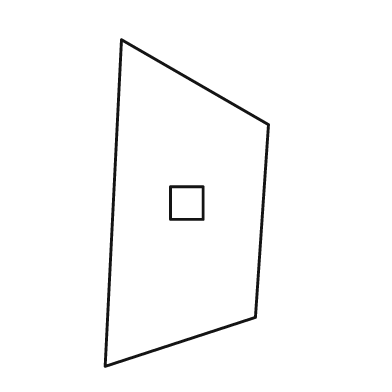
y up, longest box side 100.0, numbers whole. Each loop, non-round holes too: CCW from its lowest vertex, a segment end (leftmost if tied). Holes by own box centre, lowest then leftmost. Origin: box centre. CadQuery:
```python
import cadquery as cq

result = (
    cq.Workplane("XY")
    .moveTo(-25.0, -50.0)
    .lineTo(21.0, -35.0)
    .lineTo(25.0, 24.0)
    .lineTo(-20.0, 50.0)
    .close()
    .moveTo(-5.0, -5.0)
    .lineTo(5.0, -5.0)
    .lineTo(5.0, 5.0)
    .lineTo(-5.0, 5.0)
    .close()
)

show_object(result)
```